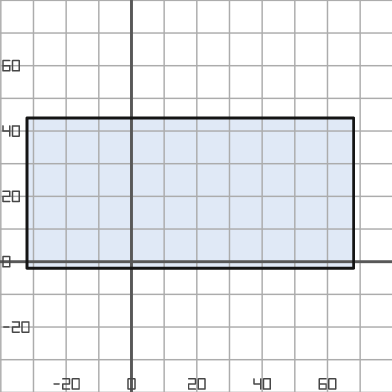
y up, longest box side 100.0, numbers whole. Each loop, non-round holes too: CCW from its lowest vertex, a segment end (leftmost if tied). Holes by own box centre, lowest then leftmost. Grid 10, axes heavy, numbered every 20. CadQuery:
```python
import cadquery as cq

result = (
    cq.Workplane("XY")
    .moveTo(-32.0, -2.0)
    .lineTo(68.0, -2.0)
    .lineTo(68.0, 44.0)
    .lineTo(-32.0, 44.0)
    .close()
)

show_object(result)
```